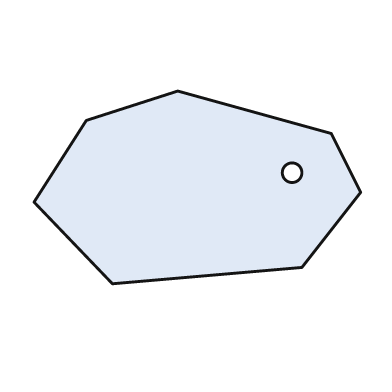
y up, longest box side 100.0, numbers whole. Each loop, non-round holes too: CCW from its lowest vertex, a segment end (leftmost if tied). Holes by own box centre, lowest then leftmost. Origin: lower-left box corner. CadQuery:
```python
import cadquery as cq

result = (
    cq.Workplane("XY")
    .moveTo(24.0, 0.0)
    .lineTo(82.0, 5.0)
    .lineTo(100.0, 28.0)
    .lineTo(91.0, 46.0)
    .lineTo(44.0, 59.0)
    .lineTo(16.0, 50.0)
    .lineTo(0.0, 25.0)
    .close()
    .moveTo(79.0, 34.0)
    .circle(3.0)
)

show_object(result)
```